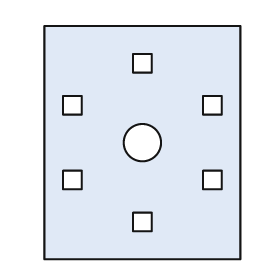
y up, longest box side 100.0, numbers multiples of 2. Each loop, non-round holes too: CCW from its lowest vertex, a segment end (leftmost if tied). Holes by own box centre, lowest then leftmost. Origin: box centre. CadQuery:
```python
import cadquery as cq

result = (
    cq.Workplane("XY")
    .moveTo(-42.0, -50.0)
    .lineTo(42.0, -50.0)
    .lineTo(42.0, 50.0)
    .lineTo(-42.0, 50.0)
    .close()
    .moveTo(-4.0, -38.0)
    .lineTo(4.0, -38.0)
    .lineTo(4.0, -30.0)
    .lineTo(-4.0, -30.0)
    .close()
    .moveTo(-34.0, -20.0)
    .lineTo(-26.0, -20.0)
    .lineTo(-26.0, -12.0)
    .lineTo(-34.0, -12.0)
    .close()
    .moveTo(26.0, -20.0)
    .lineTo(34.0, -20.0)
    .lineTo(34.0, -12.0)
    .lineTo(26.0, -12.0)
    .close()
    .moveTo(0.0, 0.0)
    .circle(8.0)
    .moveTo(-34.0, 12.0)
    .lineTo(-26.0, 12.0)
    .lineTo(-26.0, 20.0)
    .lineTo(-34.0, 20.0)
    .close()
    .moveTo(26.0, 12.0)
    .lineTo(34.0, 12.0)
    .lineTo(34.0, 20.0)
    .lineTo(26.0, 20.0)
    .close()
    .moveTo(-4.0, 30.0)
    .lineTo(4.0, 30.0)
    .lineTo(4.0, 38.0)
    .lineTo(-4.0, 38.0)
    .close()
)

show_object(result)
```